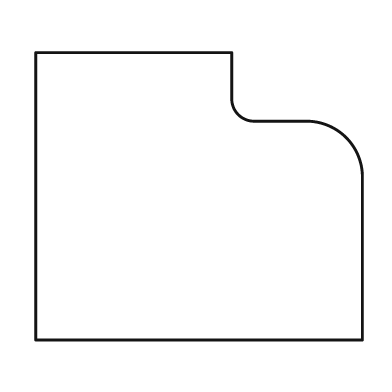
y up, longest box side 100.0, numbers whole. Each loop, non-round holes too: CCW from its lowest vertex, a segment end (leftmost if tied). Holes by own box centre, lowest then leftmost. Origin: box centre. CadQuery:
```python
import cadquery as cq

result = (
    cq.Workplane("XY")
    .moveTo(-50.0, -44.0)
    .lineTo(50.0, -44.0)
    .lineTo(50.0, 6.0)
    .threePointArc((45.0, 18.0), (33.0, 23.0))
    .lineTo(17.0, 23.0)
    .threePointArc((12.0, 25.0), (10.0, 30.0))
    .lineTo(10.0, 44.0)
    .lineTo(-50.0, 44.0)
    .close()
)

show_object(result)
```